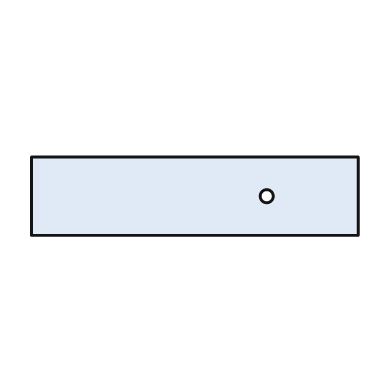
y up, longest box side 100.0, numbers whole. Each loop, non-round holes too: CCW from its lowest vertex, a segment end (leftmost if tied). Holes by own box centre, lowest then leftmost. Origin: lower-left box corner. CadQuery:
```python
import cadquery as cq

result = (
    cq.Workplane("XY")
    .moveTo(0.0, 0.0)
    .lineTo(100.0, 0.0)
    .lineTo(100.0, 24.0)
    .lineTo(0.0, 24.0)
    .close()
    .moveTo(72.0, 12.0)
    .circle(2.0)
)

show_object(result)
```